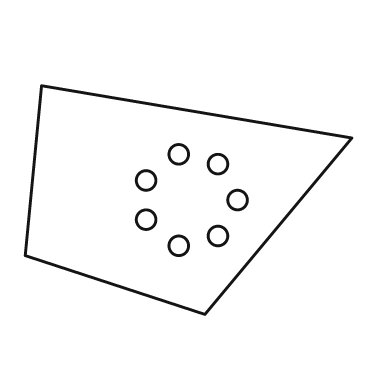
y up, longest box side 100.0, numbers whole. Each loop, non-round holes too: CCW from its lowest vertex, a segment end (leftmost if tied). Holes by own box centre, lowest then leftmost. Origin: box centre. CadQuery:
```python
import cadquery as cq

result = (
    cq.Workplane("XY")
    .moveTo(5.0, -35.0)
    .lineTo(50.0, 19.0)
    .lineTo(-45.0, 35.0)
    .lineTo(-50.0, -17.0)
    .close()
    .moveTo(-3.0, -14.0)
    .circle(3.0)
    .moveTo(9.0, -11.0)
    .circle(3.0)
    .moveTo(-13.0, -6.0)
    .circle(3.0)
    .moveTo(15.0, 0.0)
    .circle(3.0)
    .moveTo(-13.0, 6.0)
    .circle(3.0)
    .moveTo(9.0, 11.0)
    .circle(3.0)
    .moveTo(-3.0, 14.0)
    .circle(3.0)
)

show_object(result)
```